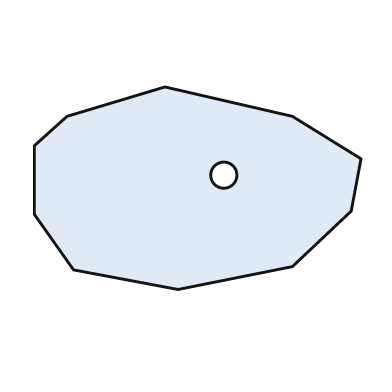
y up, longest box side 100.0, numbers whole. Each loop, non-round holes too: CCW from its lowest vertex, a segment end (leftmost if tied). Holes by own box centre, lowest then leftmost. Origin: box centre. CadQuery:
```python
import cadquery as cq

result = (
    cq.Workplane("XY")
    .moveTo(-6.0, -31.0)
    .lineTo(29.0, -24.0)
    .lineTo(47.0, -7.0)
    .lineTo(50.0, 9.0)
    .lineTo(29.0, 22.0)
    .lineTo(-10.0, 31.0)
    .lineTo(-40.0, 22.0)
    .lineTo(-50.0, 13.0)
    .lineTo(-50.0, -8.0)
    .lineTo(-38.0, -25.0)
    .close()
    .moveTo(8.0, 4.0)
    .circle(4.0)
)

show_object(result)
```